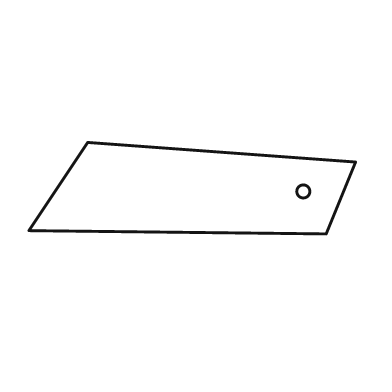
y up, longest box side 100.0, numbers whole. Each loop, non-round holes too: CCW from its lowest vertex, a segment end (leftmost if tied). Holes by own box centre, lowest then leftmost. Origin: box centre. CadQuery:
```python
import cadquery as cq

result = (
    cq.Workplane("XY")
    .moveTo(41.0, -14.0)
    .lineTo(50.0, 8.0)
    .lineTo(-32.0, 14.0)
    .lineTo(-50.0, -13.0)
    .close()
    .moveTo(34.0, -1.0)
    .circle(2.0)
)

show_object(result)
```